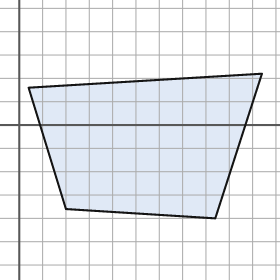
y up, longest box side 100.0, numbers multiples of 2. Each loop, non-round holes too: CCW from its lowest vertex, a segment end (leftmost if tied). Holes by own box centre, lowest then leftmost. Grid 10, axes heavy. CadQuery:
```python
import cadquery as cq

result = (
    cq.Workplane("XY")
    .moveTo(84.0, -40.0)
    .lineTo(104.0, 22.0)
    .lineTo(4.0, 16.0)
    .lineTo(20.0, -36.0)
    .close()
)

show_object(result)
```